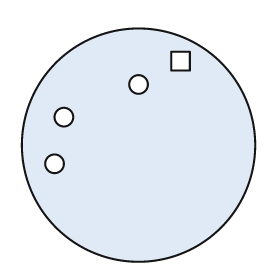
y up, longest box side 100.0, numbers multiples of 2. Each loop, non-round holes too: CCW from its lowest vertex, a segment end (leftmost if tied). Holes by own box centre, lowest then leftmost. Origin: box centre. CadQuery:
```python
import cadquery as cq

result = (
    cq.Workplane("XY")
    .moveTo(0.0, 0.0)
    .circle(50.0)
    .moveTo(-36.0, -8.0)
    .circle(4.0)
    .moveTo(-32.0, 12.0)
    .circle(4.0)
    .moveTo(0.0, 26.0)
    .circle(4.0)
    .moveTo(14.0, 32.0)
    .lineTo(22.0, 32.0)
    .lineTo(22.0, 40.0)
    .lineTo(14.0, 40.0)
    .close()
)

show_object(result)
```